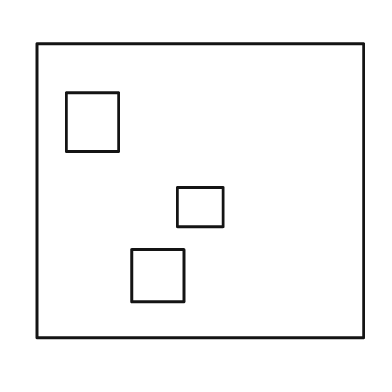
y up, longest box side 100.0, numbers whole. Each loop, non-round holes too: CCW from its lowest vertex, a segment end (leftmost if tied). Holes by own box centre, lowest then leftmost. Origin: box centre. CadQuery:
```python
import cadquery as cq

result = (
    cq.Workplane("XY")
    .moveTo(-50.0, -45.0)
    .lineTo(50.0, -45.0)
    .lineTo(50.0, 45.0)
    .lineTo(-50.0, 45.0)
    .close()
    .moveTo(-21.0, -34.0)
    .lineTo(-5.0, -34.0)
    .lineTo(-5.0, -18.0)
    .lineTo(-21.0, -18.0)
    .close()
    .moveTo(-7.0, -11.0)
    .lineTo(7.0, -11.0)
    .lineTo(7.0, 1.0)
    .lineTo(-7.0, 1.0)
    .close()
    .moveTo(-41.0, 12.0)
    .lineTo(-25.0, 12.0)
    .lineTo(-25.0, 30.0)
    .lineTo(-41.0, 30.0)
    .close()
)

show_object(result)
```